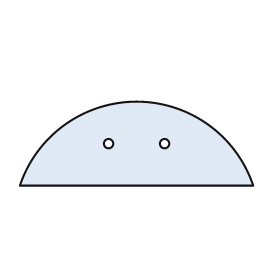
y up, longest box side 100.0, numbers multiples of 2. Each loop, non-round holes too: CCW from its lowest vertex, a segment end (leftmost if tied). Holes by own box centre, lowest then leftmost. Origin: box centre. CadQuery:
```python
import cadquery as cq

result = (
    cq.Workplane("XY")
    .moveTo(-50.0, -18.0)
    .lineTo(50.0, -18.0)
    .threePointArc((0.0, 18.0), (-50.0, -18.0))
    .close()
    .moveTo(-12.0, 0.0)
    .circle(2.0)
    .moveTo(12.0, 0.0)
    .circle(2.0)
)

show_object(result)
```